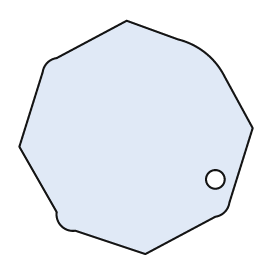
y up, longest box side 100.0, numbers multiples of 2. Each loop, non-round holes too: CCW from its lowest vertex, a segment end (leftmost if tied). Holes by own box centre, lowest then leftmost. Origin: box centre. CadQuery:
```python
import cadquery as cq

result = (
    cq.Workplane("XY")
    .moveTo(4.0, -50.0)
    .lineTo(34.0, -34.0)
    .threePointArc((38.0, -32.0), (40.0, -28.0))
    .lineTo(50.0, 4.0)
    .lineTo(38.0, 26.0)
    .threePointArc((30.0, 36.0), (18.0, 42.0))
    .lineTo(-4.0, 50.0)
    .lineTo(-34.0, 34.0)
    .threePointArc((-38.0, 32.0), (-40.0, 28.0))
    .lineTo(-50.0, -4.0)
    .lineTo(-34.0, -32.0)
    .threePointArc((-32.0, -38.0), (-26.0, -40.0))
    .close()
    .moveTo(34.0, -18.0)
    .circle(4.0)
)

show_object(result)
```